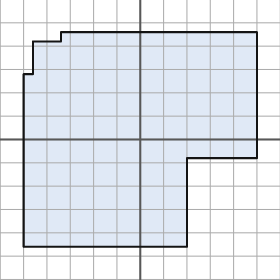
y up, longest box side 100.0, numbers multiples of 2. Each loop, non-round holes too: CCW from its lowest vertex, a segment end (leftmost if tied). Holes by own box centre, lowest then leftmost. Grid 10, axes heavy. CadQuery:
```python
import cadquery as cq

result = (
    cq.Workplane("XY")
    .moveTo(-50.0, -46.0)
    .lineTo(20.0, -46.0)
    .lineTo(20.0, -8.0)
    .lineTo(50.0, -8.0)
    .lineTo(50.0, 46.0)
    .lineTo(-34.0, 46.0)
    .lineTo(-34.0, 42.0)
    .lineTo(-46.0, 42.0)
    .lineTo(-46.0, 28.0)
    .lineTo(-50.0, 28.0)
    .close()
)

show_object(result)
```